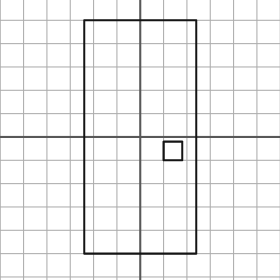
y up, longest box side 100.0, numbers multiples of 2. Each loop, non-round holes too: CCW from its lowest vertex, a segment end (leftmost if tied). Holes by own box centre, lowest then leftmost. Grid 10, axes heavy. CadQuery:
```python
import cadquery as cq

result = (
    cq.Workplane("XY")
    .moveTo(-24.0, -50.0)
    .lineTo(24.0, -50.0)
    .lineTo(24.0, 50.0)
    .lineTo(-24.0, 50.0)
    .close()
    .moveTo(10.0, -10.0)
    .lineTo(18.0, -10.0)
    .lineTo(18.0, -2.0)
    .lineTo(10.0, -2.0)
    .close()
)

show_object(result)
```